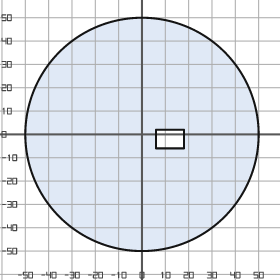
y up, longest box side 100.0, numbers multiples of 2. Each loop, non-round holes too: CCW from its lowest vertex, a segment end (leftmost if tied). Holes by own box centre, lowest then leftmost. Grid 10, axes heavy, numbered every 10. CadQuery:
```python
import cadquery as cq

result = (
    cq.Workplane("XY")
    .moveTo(0.0, 0.0)
    .circle(50.0)
    .moveTo(6.0, -6.0)
    .lineTo(18.0, -6.0)
    .lineTo(18.0, 2.0)
    .lineTo(6.0, 2.0)
    .close()
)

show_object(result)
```